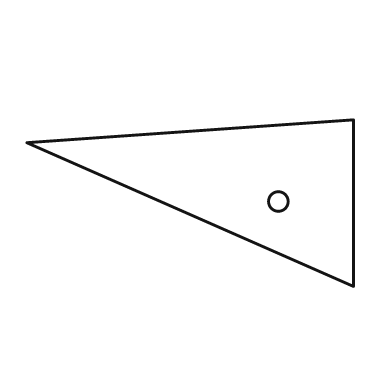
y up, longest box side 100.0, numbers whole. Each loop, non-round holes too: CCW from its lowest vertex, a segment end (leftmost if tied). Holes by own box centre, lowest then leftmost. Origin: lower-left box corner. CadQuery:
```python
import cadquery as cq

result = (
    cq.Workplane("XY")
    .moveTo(100.0, 0.0)
    .lineTo(100.0, 51.0)
    .lineTo(0.0, 44.0)
    .close()
    .moveTo(77.0, 26.0)
    .circle(3.0)
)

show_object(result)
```